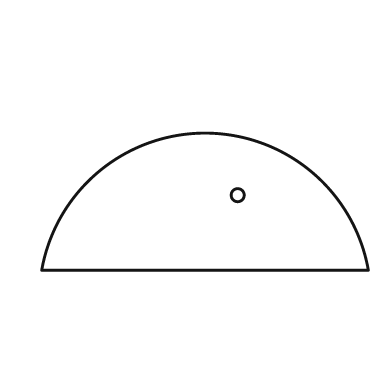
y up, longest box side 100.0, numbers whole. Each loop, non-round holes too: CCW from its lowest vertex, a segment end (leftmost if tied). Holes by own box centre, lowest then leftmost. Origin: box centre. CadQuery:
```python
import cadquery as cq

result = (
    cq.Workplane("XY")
    .moveTo(-50.0, -21.0)
    .lineTo(50.0, -21.0)
    .threePointArc((0.0, 21.0), (-50.0, -21.0))
    .close()
    .moveTo(10.0, 2.0)
    .circle(2.0)
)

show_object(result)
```